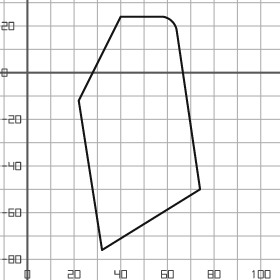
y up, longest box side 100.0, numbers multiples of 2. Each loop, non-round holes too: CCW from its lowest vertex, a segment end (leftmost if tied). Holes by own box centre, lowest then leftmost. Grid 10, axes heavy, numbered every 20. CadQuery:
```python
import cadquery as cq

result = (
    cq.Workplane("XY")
    .moveTo(32.0, -76.0)
    .lineTo(74.0, -50.0)
    .lineTo(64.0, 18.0)
    .threePointArc((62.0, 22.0), (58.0, 24.0))
    .lineTo(40.0, 24.0)
    .lineTo(22.0, -12.0)
    .close()
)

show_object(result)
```